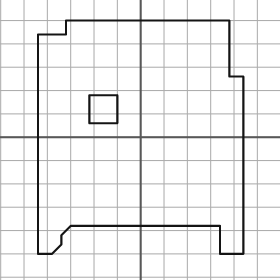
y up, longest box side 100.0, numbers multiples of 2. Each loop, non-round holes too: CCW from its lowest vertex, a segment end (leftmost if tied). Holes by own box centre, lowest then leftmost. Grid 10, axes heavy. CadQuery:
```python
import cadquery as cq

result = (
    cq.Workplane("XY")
    .moveTo(-44.0, -50.0)
    .lineTo(-38.0, -50.0)
    .lineTo(-34.0, -46.0)
    .lineTo(-34.0, -42.0)
    .lineTo(-30.0, -38.0)
    .lineTo(34.0, -38.0)
    .lineTo(34.0, -50.0)
    .lineTo(44.0, -50.0)
    .lineTo(44.0, 26.0)
    .lineTo(38.0, 26.0)
    .lineTo(38.0, 50.0)
    .lineTo(-32.0, 50.0)
    .lineTo(-32.0, 44.0)
    .lineTo(-44.0, 44.0)
    .close()
    .moveTo(-22.0, 6.0)
    .lineTo(-10.0, 6.0)
    .lineTo(-10.0, 18.0)
    .lineTo(-22.0, 18.0)
    .close()
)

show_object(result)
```